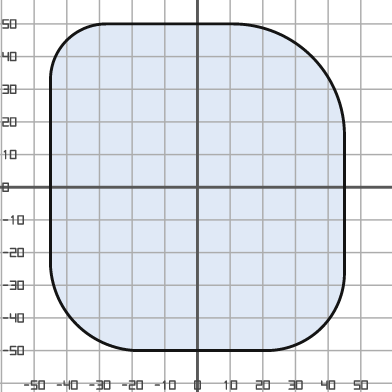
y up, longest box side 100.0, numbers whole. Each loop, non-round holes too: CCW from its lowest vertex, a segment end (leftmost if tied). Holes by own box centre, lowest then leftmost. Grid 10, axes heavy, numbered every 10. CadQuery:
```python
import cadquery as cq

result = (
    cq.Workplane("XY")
    .moveTo(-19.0, -50.0)
    .lineTo(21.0, -50.0)
    .threePointArc((38.0, -43.0), (45.0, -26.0))
    .lineTo(45.0, 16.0)
    .threePointArc((35.0, 40.0), (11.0, 50.0))
    .lineTo(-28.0, 50.0)
    .threePointArc((-40.0, 45.0), (-45.0, 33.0))
    .lineTo(-45.0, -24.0)
    .threePointArc((-37.0, -42.0), (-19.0, -50.0))
    .close()
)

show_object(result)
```